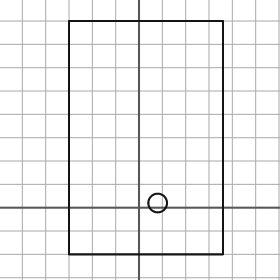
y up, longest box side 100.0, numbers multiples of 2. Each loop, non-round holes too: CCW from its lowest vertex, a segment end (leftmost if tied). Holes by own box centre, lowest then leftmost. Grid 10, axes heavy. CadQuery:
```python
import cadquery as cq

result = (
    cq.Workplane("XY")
    .moveTo(-30.0, -20.0)
    .lineTo(36.0, -20.0)
    .lineTo(36.0, 80.0)
    .lineTo(-30.0, 80.0)
    .close()
    .moveTo(8.0, 2.0)
    .circle(4.0)
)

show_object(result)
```